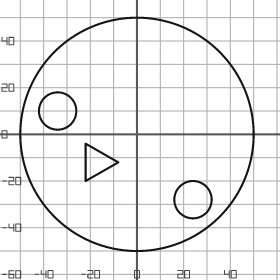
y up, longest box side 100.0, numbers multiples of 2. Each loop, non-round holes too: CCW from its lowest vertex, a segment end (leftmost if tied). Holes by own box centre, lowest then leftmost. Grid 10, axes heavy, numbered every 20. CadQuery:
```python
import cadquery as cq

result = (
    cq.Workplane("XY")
    .moveTo(0.0, 0.0)
    .circle(50.0)
    .moveTo(24.0, -28.0)
    .circle(8.0)
    .moveTo(-22.0, -20.0)
    .lineTo(-8.0, -12.0)
    .lineTo(-22.0, -4.0)
    .close()
    .moveTo(-34.0, 10.0)
    .circle(8.0)
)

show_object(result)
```